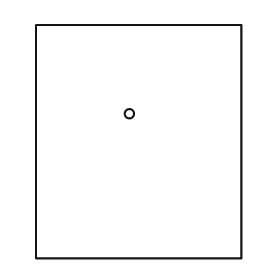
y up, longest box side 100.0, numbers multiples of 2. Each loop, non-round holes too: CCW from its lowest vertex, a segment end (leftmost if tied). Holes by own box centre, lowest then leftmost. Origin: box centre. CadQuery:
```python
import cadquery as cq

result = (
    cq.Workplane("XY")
    .moveTo(-44.0, -50.0)
    .lineTo(44.0, -50.0)
    .lineTo(44.0, 50.0)
    .lineTo(-44.0, 50.0)
    .close()
    .moveTo(-4.0, 12.0)
    .circle(2.0)
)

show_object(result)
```